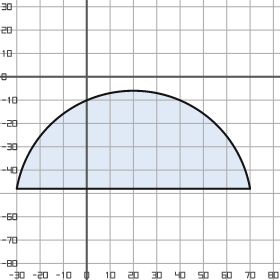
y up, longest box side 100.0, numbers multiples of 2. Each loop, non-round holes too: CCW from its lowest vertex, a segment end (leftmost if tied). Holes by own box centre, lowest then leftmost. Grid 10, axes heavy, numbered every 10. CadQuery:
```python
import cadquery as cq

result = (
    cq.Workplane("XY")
    .moveTo(-30.0, -48.0)
    .lineTo(70.0, -48.0)
    .threePointArc((20.0, -6.0), (-30.0, -48.0))
    .close()
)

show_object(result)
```